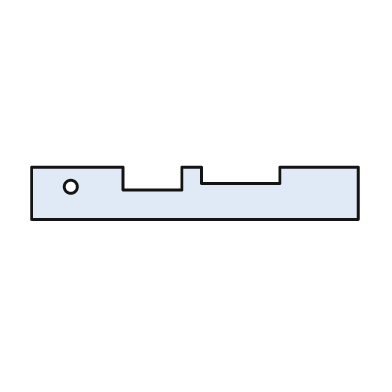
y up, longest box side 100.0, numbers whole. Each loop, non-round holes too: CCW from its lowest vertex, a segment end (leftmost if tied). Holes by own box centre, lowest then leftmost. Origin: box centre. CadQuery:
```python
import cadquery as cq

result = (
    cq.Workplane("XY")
    .moveTo(-50.0, -8.0)
    .lineTo(50.0, -8.0)
    .lineTo(50.0, 8.0)
    .lineTo(26.0, 8.0)
    .lineTo(26.0, 3.0)
    .lineTo(2.0, 3.0)
    .lineTo(2.0, 8.0)
    .lineTo(-4.0, 8.0)
    .lineTo(-4.0, 1.0)
    .lineTo(-22.0, 1.0)
    .lineTo(-22.0, 8.0)
    .lineTo(-50.0, 8.0)
    .close()
    .moveTo(-38.0, 2.0)
    .circle(2.0)
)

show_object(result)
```